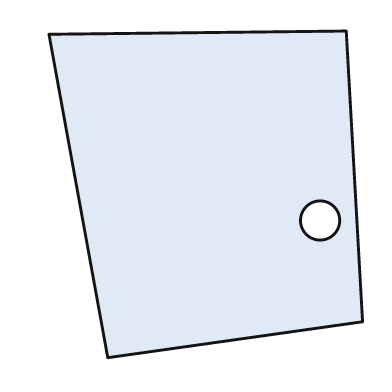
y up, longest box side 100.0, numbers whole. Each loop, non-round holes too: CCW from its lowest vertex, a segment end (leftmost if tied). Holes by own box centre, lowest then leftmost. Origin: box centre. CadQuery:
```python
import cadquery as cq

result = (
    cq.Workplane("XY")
    .moveTo(-30.0, -50.0)
    .lineTo(48.0, -39.0)
    .lineTo(43.0, 50.0)
    .lineTo(-48.0, 49.0)
    .close()
    .moveTo(35.0, -8.0)
    .circle(6.0)
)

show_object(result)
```